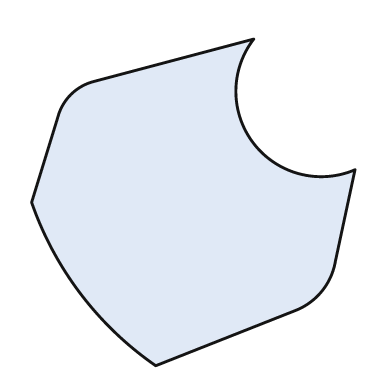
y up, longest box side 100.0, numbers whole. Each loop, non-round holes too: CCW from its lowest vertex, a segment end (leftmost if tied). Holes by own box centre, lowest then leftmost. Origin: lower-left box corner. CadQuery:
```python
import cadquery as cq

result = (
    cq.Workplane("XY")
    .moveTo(38.0, 0.0)
    .lineTo(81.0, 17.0)
    .threePointArc((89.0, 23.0), (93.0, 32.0))
    .lineTo(99.0, 60.0)
    .threePointArc((68.0, 68.0), (68.0, 100.0))
    .lineTo(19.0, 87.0)
    .threePointArc((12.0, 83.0), (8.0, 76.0))
    .lineTo(0.0, 50.0)
    .threePointArc((15.0, 22.0), (38.0, 0.0))
    .close()
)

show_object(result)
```